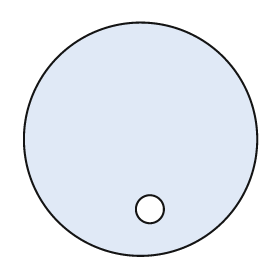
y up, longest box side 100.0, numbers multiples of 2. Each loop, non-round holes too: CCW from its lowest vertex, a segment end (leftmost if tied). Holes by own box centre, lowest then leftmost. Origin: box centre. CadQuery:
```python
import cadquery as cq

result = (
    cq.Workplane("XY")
    .moveTo(0.0, 0.0)
    .circle(50.0)
    .moveTo(4.0, -30.0)
    .circle(6.0)
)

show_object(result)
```